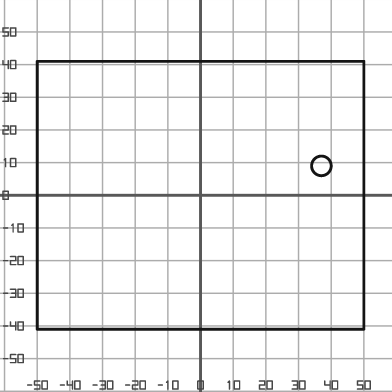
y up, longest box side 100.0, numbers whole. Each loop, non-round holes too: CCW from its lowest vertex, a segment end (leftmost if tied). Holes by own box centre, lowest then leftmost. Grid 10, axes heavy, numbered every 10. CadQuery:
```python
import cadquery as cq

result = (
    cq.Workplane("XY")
    .moveTo(-50.0, -41.0)
    .lineTo(50.0, -41.0)
    .lineTo(50.0, 41.0)
    .lineTo(-50.0, 41.0)
    .close()
    .moveTo(37.0, 9.0)
    .circle(3.0)
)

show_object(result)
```